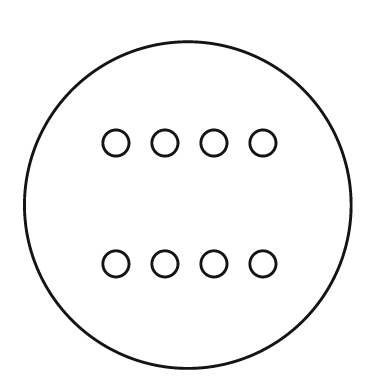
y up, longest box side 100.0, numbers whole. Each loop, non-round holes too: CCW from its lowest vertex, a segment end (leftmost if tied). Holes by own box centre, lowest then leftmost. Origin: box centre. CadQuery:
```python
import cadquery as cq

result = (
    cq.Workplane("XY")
    .moveTo(0.0, 0.0)
    .circle(50.0)
    .moveTo(-22.0, -18.0)
    .circle(4.0)
    .moveTo(-7.0, -18.0)
    .circle(4.0)
    .moveTo(8.0, -18.0)
    .circle(4.0)
    .moveTo(23.0, -18.0)
    .circle(4.0)
    .moveTo(-22.0, 19.0)
    .circle(4.0)
    .moveTo(-7.0, 19.0)
    .circle(4.0)
    .moveTo(8.0, 19.0)
    .circle(4.0)
    .moveTo(23.0, 19.0)
    .circle(4.0)
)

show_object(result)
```